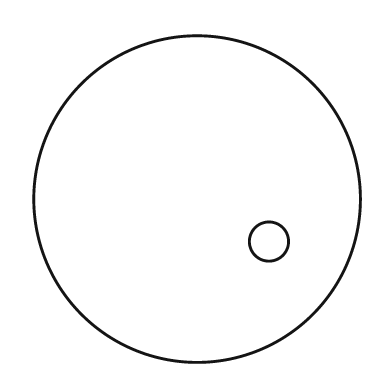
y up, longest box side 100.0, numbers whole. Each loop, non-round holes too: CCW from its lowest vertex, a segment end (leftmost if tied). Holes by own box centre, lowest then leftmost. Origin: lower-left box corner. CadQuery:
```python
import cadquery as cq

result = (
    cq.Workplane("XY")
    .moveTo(50.0, 50.0)
    .circle(50.0)
    .moveTo(72.0, 37.0)
    .circle(6.0)
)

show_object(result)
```